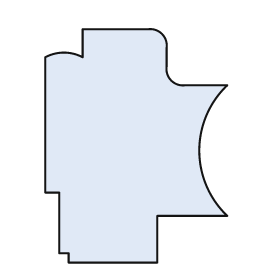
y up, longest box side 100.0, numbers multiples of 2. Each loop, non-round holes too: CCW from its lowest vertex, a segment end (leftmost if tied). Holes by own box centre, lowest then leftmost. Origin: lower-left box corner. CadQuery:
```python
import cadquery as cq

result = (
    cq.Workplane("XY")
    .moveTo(10.0, 0.0)
    .lineTo(48.0, 0.0)
    .lineTo(48.0, 20.0)
    .lineTo(78.0, 20.0)
    .threePointArc((66.0, 48.0), (78.0, 76.0))
    .lineTo(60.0, 76.0)
    .threePointArc((54.0, 78.0), (52.0, 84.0))
    .lineTo(52.0, 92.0)
    .threePointArc((50.0, 98.0), (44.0, 100.0))
    .lineTo(16.0, 100.0)
    .lineTo(16.0, 88.0)
    .threePointArc((8.0, 90.0), (0.0, 88.0))
    .lineTo(0.0, 30.0)
    .lineTo(6.0, 30.0)
    .lineTo(6.0, 4.0)
    .lineTo(10.0, 4.0)
    .close()
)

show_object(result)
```